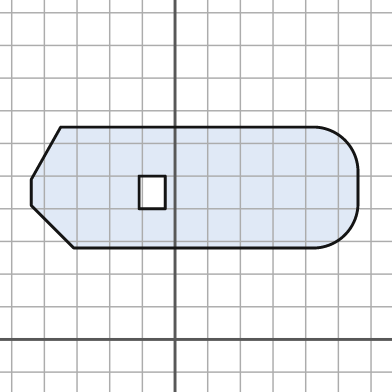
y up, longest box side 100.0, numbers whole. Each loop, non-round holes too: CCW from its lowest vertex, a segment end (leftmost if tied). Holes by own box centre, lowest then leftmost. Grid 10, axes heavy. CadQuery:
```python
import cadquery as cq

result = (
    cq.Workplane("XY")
    .moveTo(-31.0, 28.0)
    .lineTo(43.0, 28.0)
    .threePointArc((52.0, 32.0), (56.0, 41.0))
    .lineTo(56.0, 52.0)
    .threePointArc((52.0, 61.0), (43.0, 65.0))
    .lineTo(-35.0, 65.0)
    .lineTo(-44.0, 49.0)
    .lineTo(-44.0, 41.0)
    .close()
    .moveTo(-11.0, 40.0)
    .lineTo(-3.0, 40.0)
    .lineTo(-3.0, 50.0)
    .lineTo(-11.0, 50.0)
    .close()
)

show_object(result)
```